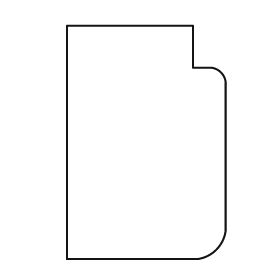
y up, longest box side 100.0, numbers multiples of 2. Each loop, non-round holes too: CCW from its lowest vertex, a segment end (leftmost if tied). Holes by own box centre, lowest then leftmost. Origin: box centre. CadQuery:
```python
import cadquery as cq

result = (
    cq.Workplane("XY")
    .moveTo(-34.0, -50.0)
    .lineTo(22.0, -50.0)
    .threePointArc((30.0, -46.0), (34.0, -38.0))
    .lineTo(34.0, 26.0)
    .threePointArc((32.0, 30.0), (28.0, 32.0))
    .lineTo(20.0, 32.0)
    .lineTo(20.0, 50.0)
    .lineTo(-34.0, 50.0)
    .close()
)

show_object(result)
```